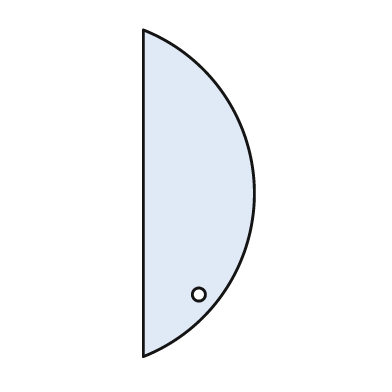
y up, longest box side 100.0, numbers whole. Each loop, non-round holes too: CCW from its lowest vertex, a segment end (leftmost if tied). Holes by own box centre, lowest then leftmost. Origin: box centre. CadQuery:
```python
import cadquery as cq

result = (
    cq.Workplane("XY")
    .moveTo(-17.0, -50.0)
    .threePointArc((17.0, 0.0), (-17.0, 50.0))
    .close()
    .moveTo(0.0, -31.0)
    .circle(2.0)
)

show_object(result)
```